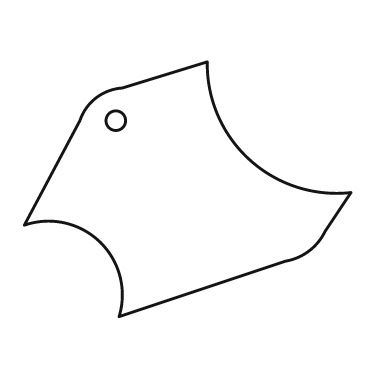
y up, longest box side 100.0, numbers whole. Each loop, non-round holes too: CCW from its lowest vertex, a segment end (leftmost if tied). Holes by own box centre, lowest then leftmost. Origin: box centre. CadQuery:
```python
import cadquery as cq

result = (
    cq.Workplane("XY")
    .moveTo(-21.0, -39.0)
    .lineTo(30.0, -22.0)
    .threePointArc((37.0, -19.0), (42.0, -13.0))
    .lineTo(50.0, -1.0)
    .threePointArc((19.0, 9.0), (6.0, 39.0))
    .lineTo(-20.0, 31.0)
    .threePointArc((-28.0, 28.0), (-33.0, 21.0))
    .lineTo(-50.0, -11.0)
    .threePointArc((-27.0, -16.0), (-21.0, -39.0))
    .close()
    .moveTo(-22.0, 21.0)
    .circle(3.0)
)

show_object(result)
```